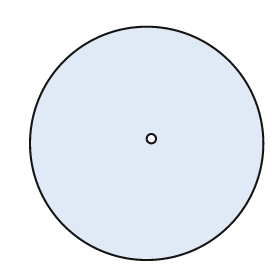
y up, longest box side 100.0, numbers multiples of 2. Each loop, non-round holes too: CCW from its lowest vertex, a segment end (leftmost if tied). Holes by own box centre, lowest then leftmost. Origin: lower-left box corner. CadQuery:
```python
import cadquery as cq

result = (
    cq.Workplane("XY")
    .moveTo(50.0, 50.0)
    .circle(50.0)
    .moveTo(52.0, 52.0)
    .circle(2.0)
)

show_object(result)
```